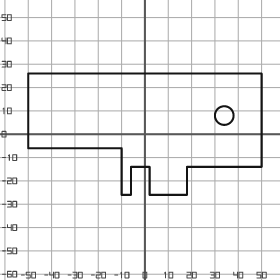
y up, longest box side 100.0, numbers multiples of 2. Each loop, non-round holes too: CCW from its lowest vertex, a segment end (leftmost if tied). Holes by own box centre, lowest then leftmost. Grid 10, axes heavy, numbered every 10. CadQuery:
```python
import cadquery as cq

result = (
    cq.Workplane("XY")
    .moveTo(-10.0, -26.0)
    .lineTo(-6.0, -26.0)
    .lineTo(-6.0, -14.0)
    .lineTo(2.0, -14.0)
    .lineTo(2.0, -26.0)
    .lineTo(18.0, -26.0)
    .lineTo(18.0, -14.0)
    .lineTo(50.0, -14.0)
    .lineTo(50.0, 26.0)
    .lineTo(-50.0, 26.0)
    .lineTo(-50.0, -6.0)
    .lineTo(-10.0, -6.0)
    .close()
    .moveTo(34.0, 8.0)
    .circle(4.0)
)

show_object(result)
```